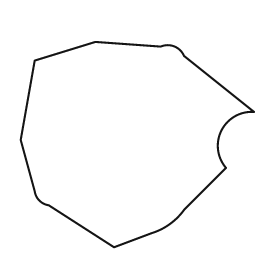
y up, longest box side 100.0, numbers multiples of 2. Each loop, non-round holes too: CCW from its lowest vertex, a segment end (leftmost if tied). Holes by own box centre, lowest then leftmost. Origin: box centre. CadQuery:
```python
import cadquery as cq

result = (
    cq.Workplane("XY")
    .moveTo(-10.0, -44.0)
    .lineTo(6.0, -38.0)
    .threePointArc((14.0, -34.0), (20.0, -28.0))
    .lineTo(38.0, -10.0)
    .threePointArc((36.0, 6.0), (50.0, 14.0))
    .lineTo(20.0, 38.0)
    .threePointArc((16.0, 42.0), (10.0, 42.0))
    .lineTo(-18.0, 44.0)
    .lineTo(-44.0, 36.0)
    .lineTo(-50.0, 2.0)
    .lineTo(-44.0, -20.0)
    .threePointArc((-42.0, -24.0), (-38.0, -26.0))
    .close()
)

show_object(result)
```